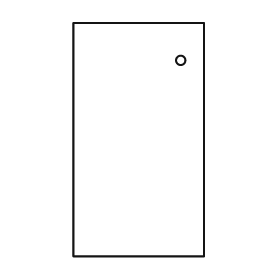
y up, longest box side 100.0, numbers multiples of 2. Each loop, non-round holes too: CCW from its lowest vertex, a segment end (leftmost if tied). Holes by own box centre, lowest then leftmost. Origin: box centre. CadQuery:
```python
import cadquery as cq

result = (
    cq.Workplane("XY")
    .moveTo(-28.0, -50.0)
    .lineTo(28.0, -50.0)
    .lineTo(28.0, 50.0)
    .lineTo(-28.0, 50.0)
    .close()
    .moveTo(18.0, 34.0)
    .circle(2.0)
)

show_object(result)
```